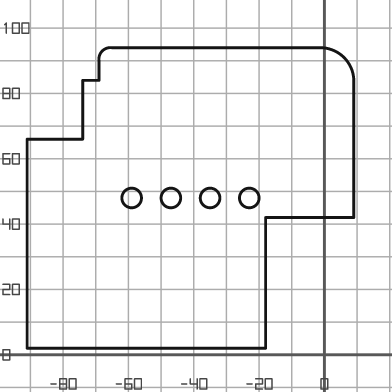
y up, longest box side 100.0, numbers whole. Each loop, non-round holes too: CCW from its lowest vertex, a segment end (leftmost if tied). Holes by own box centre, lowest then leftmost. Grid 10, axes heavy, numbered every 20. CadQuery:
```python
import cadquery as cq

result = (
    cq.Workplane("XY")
    .moveTo(-91.0, 2.0)
    .lineTo(-18.0, 2.0)
    .lineTo(-18.0, 42.0)
    .lineTo(9.0, 42.0)
    .lineTo(9.0, 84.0)
    .threePointArc((6.0, 91.0), (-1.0, 94.0))
    .lineTo(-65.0, 94.0)
    .threePointArc((-68.0, 93.0), (-69.0, 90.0))
    .lineTo(-69.0, 84.0)
    .lineTo(-74.0, 84.0)
    .lineTo(-74.0, 66.0)
    .lineTo(-91.0, 66.0)
    .close()
    .moveTo(-59.0, 48.0)
    .circle(3.0)
    .moveTo(-47.0, 48.0)
    .circle(3.0)
    .moveTo(-35.0, 48.0)
    .circle(3.0)
    .moveTo(-23.0, 48.0)
    .circle(3.0)
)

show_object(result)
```